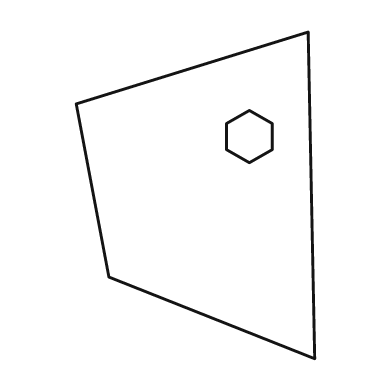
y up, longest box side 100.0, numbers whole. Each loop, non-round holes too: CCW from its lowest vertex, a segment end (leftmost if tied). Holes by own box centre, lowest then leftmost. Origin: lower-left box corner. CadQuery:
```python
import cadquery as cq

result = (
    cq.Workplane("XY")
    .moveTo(73.0, 0.0)
    .lineTo(71.0, 100.0)
    .lineTo(0.0, 78.0)
    .lineTo(10.0, 25.0)
    .close()
    .moveTo(53.0, 60.0)
    .lineTo(60.0, 64.0)
    .lineTo(60.0, 72.0)
    .lineTo(53.0, 76.0)
    .lineTo(46.0, 72.0)
    .lineTo(46.0, 64.0)
    .close()
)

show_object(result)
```